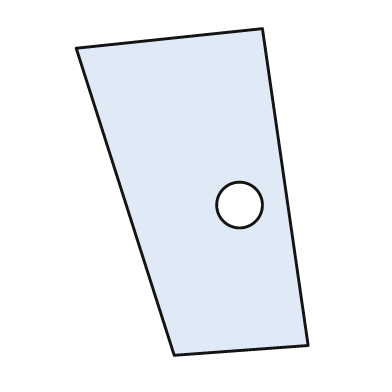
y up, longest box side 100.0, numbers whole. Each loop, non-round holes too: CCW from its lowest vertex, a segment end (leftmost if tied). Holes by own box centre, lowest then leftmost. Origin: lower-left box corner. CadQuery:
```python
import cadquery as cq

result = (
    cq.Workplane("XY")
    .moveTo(30.0, 0.0)
    .lineTo(71.0, 3.0)
    .lineTo(57.0, 100.0)
    .lineTo(0.0, 94.0)
    .close()
    .moveTo(50.0, 46.0)
    .circle(7.0)
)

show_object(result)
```